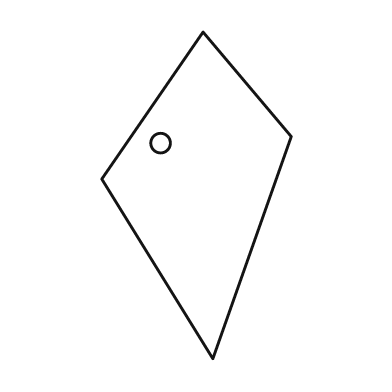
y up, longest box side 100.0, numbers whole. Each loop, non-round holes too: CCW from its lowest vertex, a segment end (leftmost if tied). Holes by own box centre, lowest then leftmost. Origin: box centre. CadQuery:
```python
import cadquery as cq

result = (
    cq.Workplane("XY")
    .moveTo(5.0, -50.0)
    .lineTo(29.0, 18.0)
    .lineTo(2.0, 50.0)
    .lineTo(-29.0, 5.0)
    .close()
    .moveTo(-11.0, 16.0)
    .circle(3.0)
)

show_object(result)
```